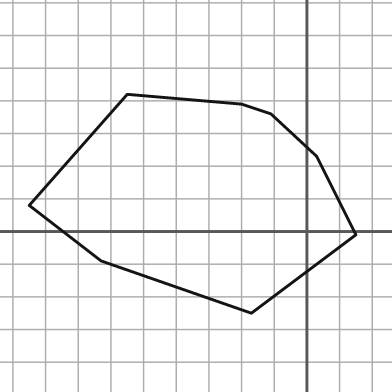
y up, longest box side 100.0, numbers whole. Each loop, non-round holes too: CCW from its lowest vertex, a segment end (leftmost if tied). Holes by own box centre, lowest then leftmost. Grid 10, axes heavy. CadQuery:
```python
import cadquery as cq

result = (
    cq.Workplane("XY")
    .moveTo(-17.0, -25.0)
    .lineTo(15.0, -1.0)
    .lineTo(3.0, 23.0)
    .lineTo(-11.0, 36.0)
    .lineTo(-20.0, 39.0)
    .lineTo(-55.0, 42.0)
    .lineTo(-85.0, 8.0)
    .lineTo(-63.0, -9.0)
    .close()
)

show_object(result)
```